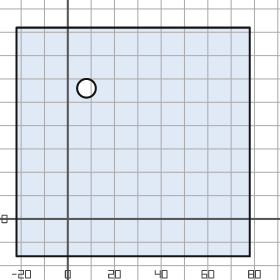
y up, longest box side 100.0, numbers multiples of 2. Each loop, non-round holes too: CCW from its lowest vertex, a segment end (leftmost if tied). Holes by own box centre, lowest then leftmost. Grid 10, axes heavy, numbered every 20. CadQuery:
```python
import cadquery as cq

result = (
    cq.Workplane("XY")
    .moveTo(-22.0, -16.0)
    .lineTo(78.0, -16.0)
    .lineTo(78.0, 82.0)
    .lineTo(-22.0, 82.0)
    .close()
    .moveTo(8.0, 56.0)
    .circle(4.0)
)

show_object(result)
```